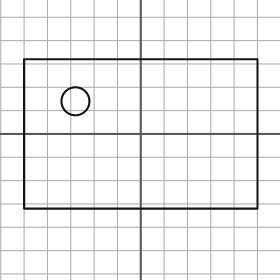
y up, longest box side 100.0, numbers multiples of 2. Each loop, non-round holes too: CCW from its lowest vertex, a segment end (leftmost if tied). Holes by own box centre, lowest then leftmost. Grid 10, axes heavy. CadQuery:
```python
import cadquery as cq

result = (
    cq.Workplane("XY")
    .moveTo(-50.0, -32.0)
    .lineTo(50.0, -32.0)
    .lineTo(50.0, 32.0)
    .lineTo(-50.0, 32.0)
    .close()
    .moveTo(-28.0, 14.0)
    .circle(6.0)
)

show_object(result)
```